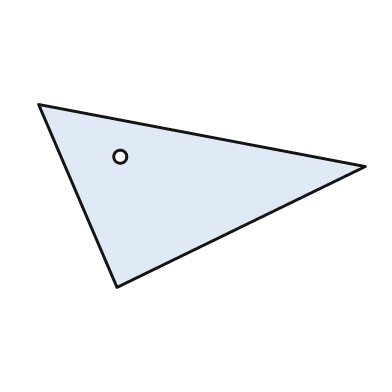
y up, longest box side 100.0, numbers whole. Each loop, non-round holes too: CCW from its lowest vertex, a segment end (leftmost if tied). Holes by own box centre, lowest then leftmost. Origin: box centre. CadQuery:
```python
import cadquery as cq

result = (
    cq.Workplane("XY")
    .moveTo(-26.0, -28.0)
    .lineTo(50.0, 9.0)
    .lineTo(-50.0, 28.0)
    .close()
    .moveTo(-25.0, 12.0)
    .circle(2.0)
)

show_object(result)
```